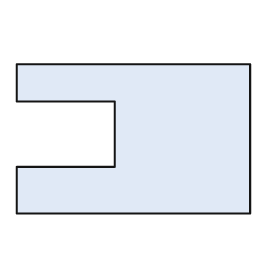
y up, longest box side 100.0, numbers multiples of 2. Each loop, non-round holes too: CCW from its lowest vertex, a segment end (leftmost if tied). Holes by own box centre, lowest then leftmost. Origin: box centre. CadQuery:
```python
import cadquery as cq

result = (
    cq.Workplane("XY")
    .moveTo(-50.0, -32.0)
    .lineTo(50.0, -32.0)
    .lineTo(50.0, 32.0)
    .lineTo(-50.0, 32.0)
    .lineTo(-50.0, 16.0)
    .lineTo(-8.0, 16.0)
    .lineTo(-8.0, -12.0)
    .lineTo(-50.0, -12.0)
    .close()
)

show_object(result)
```